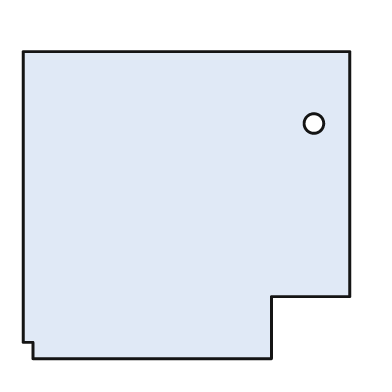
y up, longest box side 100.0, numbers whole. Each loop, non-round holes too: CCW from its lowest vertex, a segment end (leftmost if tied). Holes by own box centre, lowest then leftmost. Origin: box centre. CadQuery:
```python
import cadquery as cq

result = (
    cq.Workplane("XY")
    .moveTo(-47.0, -47.0)
    .lineTo(26.0, -47.0)
    .lineTo(26.0, -28.0)
    .lineTo(50.0, -28.0)
    .lineTo(50.0, 47.0)
    .lineTo(-50.0, 47.0)
    .lineTo(-50.0, -42.0)
    .lineTo(-47.0, -42.0)
    .close()
    .moveTo(39.0, 25.0)
    .circle(3.0)
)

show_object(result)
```